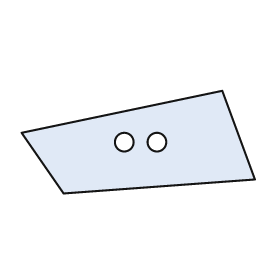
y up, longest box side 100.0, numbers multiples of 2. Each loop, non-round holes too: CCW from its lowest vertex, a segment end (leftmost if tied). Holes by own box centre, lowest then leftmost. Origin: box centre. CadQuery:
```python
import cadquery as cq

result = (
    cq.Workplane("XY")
    .moveTo(-32.0, -22.0)
    .lineTo(50.0, -16.0)
    .lineTo(36.0, 22.0)
    .lineTo(-50.0, 4.0)
    .close()
    .moveTo(-6.0, 0.0)
    .circle(4.0)
    .moveTo(8.0, 0.0)
    .circle(4.0)
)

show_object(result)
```